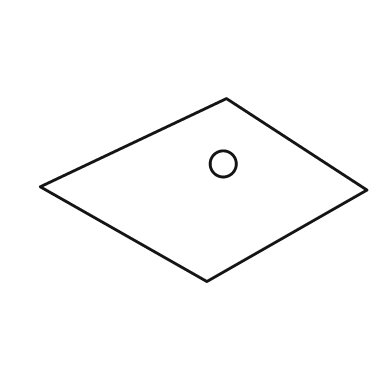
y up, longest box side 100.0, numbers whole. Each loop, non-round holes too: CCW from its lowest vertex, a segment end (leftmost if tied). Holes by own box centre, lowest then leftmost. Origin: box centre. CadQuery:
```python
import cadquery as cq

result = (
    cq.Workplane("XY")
    .moveTo(1.0, -28.0)
    .lineTo(50.0, 0.0)
    .lineTo(7.0, 28.0)
    .lineTo(-50.0, 1.0)
    .close()
    .moveTo(6.0, 8.0)
    .circle(4.0)
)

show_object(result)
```